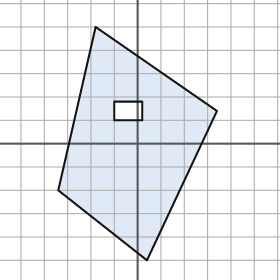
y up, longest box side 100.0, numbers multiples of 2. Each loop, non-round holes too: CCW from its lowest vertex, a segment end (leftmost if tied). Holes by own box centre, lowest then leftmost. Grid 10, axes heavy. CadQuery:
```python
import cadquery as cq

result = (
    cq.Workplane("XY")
    .moveTo(4.0, -50.0)
    .lineTo(34.0, 14.0)
    .lineTo(-18.0, 50.0)
    .lineTo(-34.0, -20.0)
    .close()
    .moveTo(-10.0, 10.0)
    .lineTo(2.0, 10.0)
    .lineTo(2.0, 18.0)
    .lineTo(-10.0, 18.0)
    .close()
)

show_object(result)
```